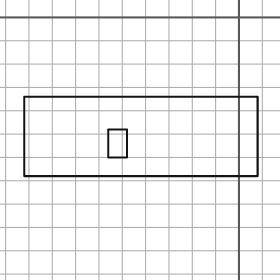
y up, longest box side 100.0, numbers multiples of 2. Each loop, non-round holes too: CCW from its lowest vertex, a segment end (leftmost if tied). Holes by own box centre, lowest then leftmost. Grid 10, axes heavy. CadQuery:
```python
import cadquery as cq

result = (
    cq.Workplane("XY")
    .moveTo(-92.0, -68.0)
    .lineTo(8.0, -68.0)
    .lineTo(8.0, -34.0)
    .lineTo(-92.0, -34.0)
    .close()
    .moveTo(-56.0, -60.0)
    .lineTo(-48.0, -60.0)
    .lineTo(-48.0, -48.0)
    .lineTo(-56.0, -48.0)
    .close()
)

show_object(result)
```